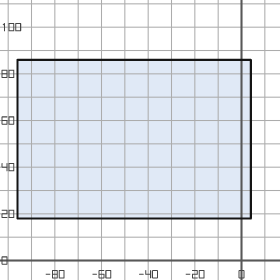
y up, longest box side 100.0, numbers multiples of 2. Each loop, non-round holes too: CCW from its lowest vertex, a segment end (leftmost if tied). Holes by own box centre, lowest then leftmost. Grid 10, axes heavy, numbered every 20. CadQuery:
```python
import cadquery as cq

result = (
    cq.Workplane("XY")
    .moveTo(-96.0, 18.0)
    .lineTo(4.0, 18.0)
    .lineTo(4.0, 86.0)
    .lineTo(-96.0, 86.0)
    .close()
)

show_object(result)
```